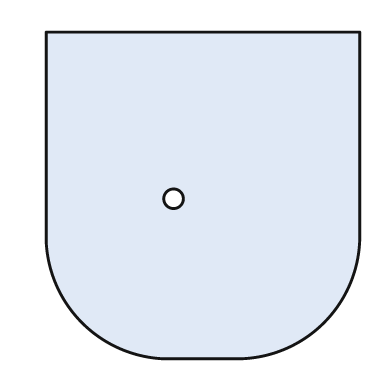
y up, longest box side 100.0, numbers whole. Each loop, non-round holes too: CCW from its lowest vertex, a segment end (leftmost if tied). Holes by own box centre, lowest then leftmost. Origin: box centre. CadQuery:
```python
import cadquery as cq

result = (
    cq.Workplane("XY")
    .moveTo(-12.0, -50.0)
    .lineTo(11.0, -50.0)
    .threePointArc((37.0, -39.0), (48.0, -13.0))
    .lineTo(48.0, 50.0)
    .lineTo(-48.0, 50.0)
    .lineTo(-48.0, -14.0)
    .threePointArc((-37.0, -39.0), (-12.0, -50.0))
    .close()
    .moveTo(-9.0, -1.0)
    .circle(3.0)
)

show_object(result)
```